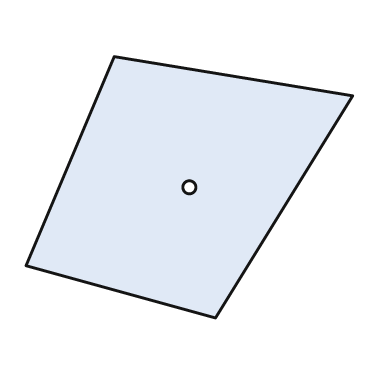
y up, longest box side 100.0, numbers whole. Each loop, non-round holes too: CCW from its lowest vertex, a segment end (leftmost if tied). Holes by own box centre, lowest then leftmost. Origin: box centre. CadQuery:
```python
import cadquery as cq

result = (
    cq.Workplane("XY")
    .moveTo(8.0, -40.0)
    .lineTo(50.0, 28.0)
    .lineTo(-23.0, 40.0)
    .lineTo(-50.0, -24.0)
    .close()
    .moveTo(0.0, 0.0)
    .circle(2.0)
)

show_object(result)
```